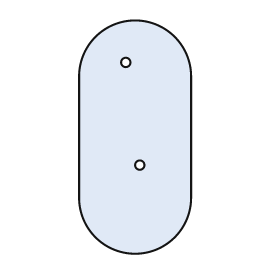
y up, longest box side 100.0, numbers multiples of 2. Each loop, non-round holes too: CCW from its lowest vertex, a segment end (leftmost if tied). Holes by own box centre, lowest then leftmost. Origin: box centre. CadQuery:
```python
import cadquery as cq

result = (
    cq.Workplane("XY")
    .moveTo(-24.0, -26.0)
    .threePointArc((0.0, -50.0), (24.0, -26.0))
    .lineTo(24.0, 26.0)
    .threePointArc((0.0, 50.0), (-24.0, 26.0))
    .close()
    .moveTo(2.0, -12.0)
    .circle(2.0)
    .moveTo(-4.0, 32.0)
    .circle(2.0)
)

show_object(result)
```